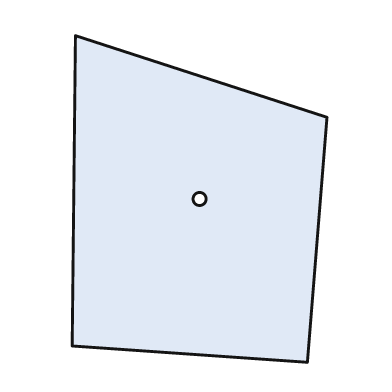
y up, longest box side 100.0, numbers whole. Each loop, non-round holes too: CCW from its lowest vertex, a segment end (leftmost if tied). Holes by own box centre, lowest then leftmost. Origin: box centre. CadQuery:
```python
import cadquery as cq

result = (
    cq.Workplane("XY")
    .moveTo(33.0, -50.0)
    .lineTo(39.0, 25.0)
    .lineTo(-38.0, 50.0)
    .lineTo(-39.0, -45.0)
    .close()
    .moveTo(0.0, 0.0)
    .circle(2.0)
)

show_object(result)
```